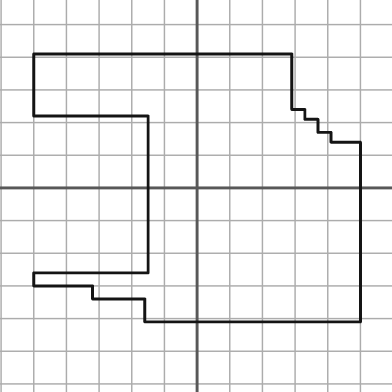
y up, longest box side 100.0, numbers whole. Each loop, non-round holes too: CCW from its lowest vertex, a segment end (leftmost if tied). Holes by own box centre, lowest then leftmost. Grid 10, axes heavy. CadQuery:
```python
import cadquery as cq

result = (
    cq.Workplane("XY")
    .moveTo(-16.0, -41.0)
    .lineTo(50.0, -41.0)
    .lineTo(50.0, 14.0)
    .lineTo(41.0, 14.0)
    .lineTo(41.0, 17.0)
    .lineTo(37.0, 17.0)
    .lineTo(37.0, 21.0)
    .lineTo(33.0, 21.0)
    .lineTo(33.0, 24.0)
    .lineTo(29.0, 24.0)
    .lineTo(29.0, 41.0)
    .lineTo(-50.0, 41.0)
    .lineTo(-50.0, 22.0)
    .lineTo(-15.0, 22.0)
    .lineTo(-15.0, -26.0)
    .lineTo(-50.0, -26.0)
    .lineTo(-50.0, -30.0)
    .lineTo(-32.0, -30.0)
    .lineTo(-32.0, -34.0)
    .lineTo(-16.0, -34.0)
    .close()
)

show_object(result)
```